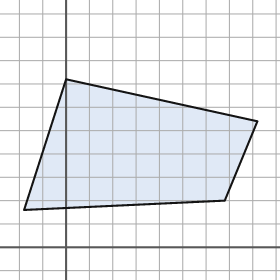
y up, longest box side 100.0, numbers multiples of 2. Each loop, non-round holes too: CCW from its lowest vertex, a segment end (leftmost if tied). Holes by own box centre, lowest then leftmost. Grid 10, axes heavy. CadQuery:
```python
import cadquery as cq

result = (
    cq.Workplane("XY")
    .moveTo(-18.0, 16.0)
    .lineTo(68.0, 20.0)
    .lineTo(82.0, 54.0)
    .lineTo(0.0, 72.0)
    .close()
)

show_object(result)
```